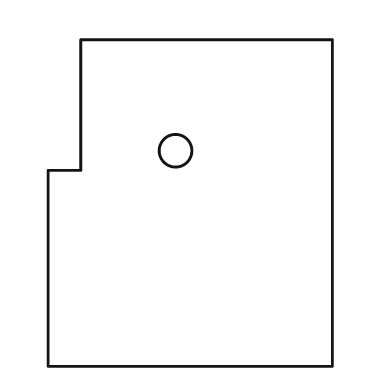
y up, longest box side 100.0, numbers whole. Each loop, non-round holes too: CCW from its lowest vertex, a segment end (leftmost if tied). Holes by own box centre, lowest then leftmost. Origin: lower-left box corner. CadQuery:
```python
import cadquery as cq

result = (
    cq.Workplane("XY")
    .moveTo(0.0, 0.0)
    .lineTo(87.0, 0.0)
    .lineTo(87.0, 100.0)
    .lineTo(10.0, 100.0)
    .lineTo(10.0, 60.0)
    .lineTo(0.0, 60.0)
    .close()
    .moveTo(39.0, 66.0)
    .circle(5.0)
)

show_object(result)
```